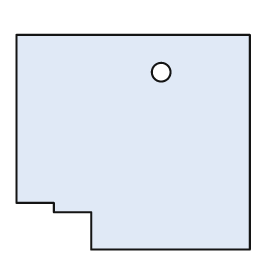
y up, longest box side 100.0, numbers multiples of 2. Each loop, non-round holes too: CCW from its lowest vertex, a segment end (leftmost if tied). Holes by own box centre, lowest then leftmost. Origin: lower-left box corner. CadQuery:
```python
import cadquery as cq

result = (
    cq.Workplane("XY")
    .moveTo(32.0, 0.0)
    .lineTo(100.0, 0.0)
    .lineTo(100.0, 92.0)
    .lineTo(0.0, 92.0)
    .lineTo(0.0, 20.0)
    .lineTo(16.0, 20.0)
    .lineTo(16.0, 16.0)
    .lineTo(32.0, 16.0)
    .close()
    .moveTo(62.0, 76.0)
    .circle(4.0)
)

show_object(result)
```